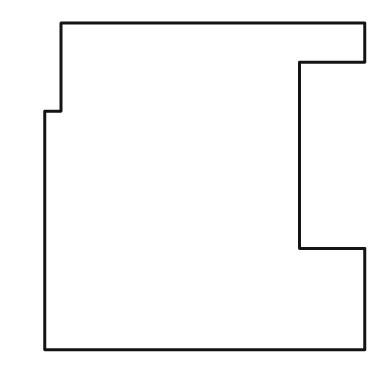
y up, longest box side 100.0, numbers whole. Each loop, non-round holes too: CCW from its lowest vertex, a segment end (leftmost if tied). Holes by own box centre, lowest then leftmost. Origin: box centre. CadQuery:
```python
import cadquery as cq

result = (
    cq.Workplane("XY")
    .moveTo(-49.0, -50.0)
    .lineTo(49.0, -50.0)
    .lineTo(49.0, -19.0)
    .lineTo(29.0, -19.0)
    .lineTo(29.0, 38.0)
    .lineTo(49.0, 38.0)
    .lineTo(49.0, 50.0)
    .lineTo(-44.0, 50.0)
    .lineTo(-44.0, 23.0)
    .lineTo(-49.0, 23.0)
    .close()
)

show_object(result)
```